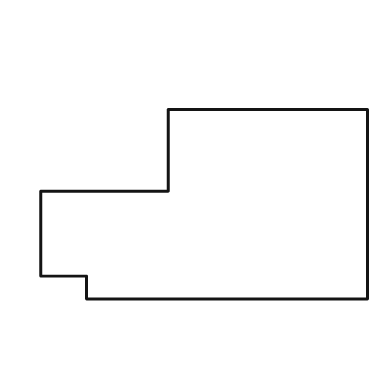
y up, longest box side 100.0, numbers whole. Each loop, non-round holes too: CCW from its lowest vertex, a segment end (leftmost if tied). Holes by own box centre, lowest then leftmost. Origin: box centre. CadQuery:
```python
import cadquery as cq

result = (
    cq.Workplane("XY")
    .moveTo(-36.0, -29.0)
    .lineTo(50.0, -29.0)
    .lineTo(50.0, 29.0)
    .lineTo(-11.0, 29.0)
    .lineTo(-11.0, 4.0)
    .lineTo(-50.0, 4.0)
    .lineTo(-50.0, -22.0)
    .lineTo(-36.0, -22.0)
    .close()
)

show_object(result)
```